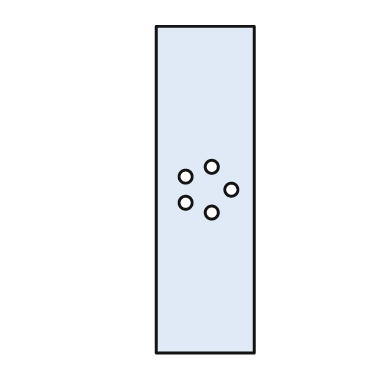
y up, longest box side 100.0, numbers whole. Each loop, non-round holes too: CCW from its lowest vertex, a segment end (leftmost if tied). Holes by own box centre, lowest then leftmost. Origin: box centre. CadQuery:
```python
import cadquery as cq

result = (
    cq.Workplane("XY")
    .moveTo(-15.0, -50.0)
    .lineTo(15.0, -50.0)
    .lineTo(15.0, 50.0)
    .lineTo(-15.0, 50.0)
    .close()
    .moveTo(2.0, -7.0)
    .circle(2.0)
    .moveTo(-6.0, -4.0)
    .circle(2.0)
    .moveTo(8.0, 0.0)
    .circle(2.0)
    .moveTo(-6.0, 4.0)
    .circle(2.0)
    .moveTo(2.0, 7.0)
    .circle(2.0)
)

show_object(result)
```